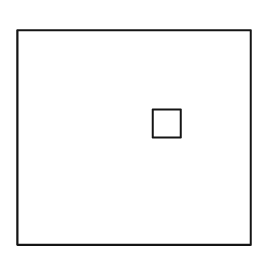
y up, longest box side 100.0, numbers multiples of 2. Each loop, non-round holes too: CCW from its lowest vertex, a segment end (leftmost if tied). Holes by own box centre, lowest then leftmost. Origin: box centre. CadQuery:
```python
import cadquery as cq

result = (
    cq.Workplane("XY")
    .moveTo(-50.0, -46.0)
    .lineTo(50.0, -46.0)
    .lineTo(50.0, 46.0)
    .lineTo(-50.0, 46.0)
    .close()
    .moveTo(8.0, 0.0)
    .lineTo(20.0, 0.0)
    .lineTo(20.0, 12.0)
    .lineTo(8.0, 12.0)
    .close()
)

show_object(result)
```